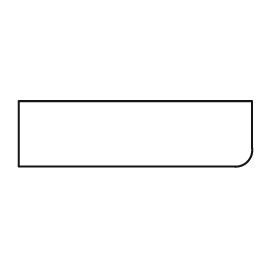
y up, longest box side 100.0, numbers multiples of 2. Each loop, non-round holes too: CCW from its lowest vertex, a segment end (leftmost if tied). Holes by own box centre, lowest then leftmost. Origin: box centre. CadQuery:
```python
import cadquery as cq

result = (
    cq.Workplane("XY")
    .moveTo(-50.0, -14.0)
    .lineTo(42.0, -14.0)
    .threePointArc((48.0, -12.0), (50.0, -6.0))
    .lineTo(50.0, 14.0)
    .lineTo(-50.0, 14.0)
    .close()
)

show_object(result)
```